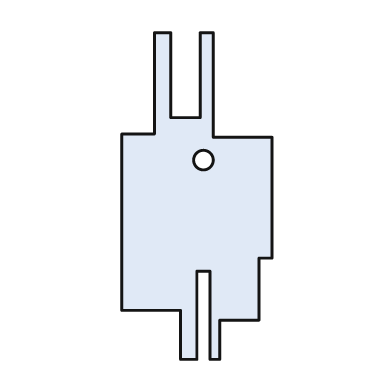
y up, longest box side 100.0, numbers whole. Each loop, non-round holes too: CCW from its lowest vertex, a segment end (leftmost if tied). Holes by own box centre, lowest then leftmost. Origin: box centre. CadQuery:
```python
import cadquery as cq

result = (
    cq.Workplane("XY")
    .moveTo(-5.0, -50.0)
    .lineTo(0.0, -50.0)
    .lineTo(0.0, -23.0)
    .lineTo(4.0, -23.0)
    .lineTo(4.0, -50.0)
    .lineTo(7.0, -50.0)
    .lineTo(7.0, -38.0)
    .lineTo(19.0, -38.0)
    .lineTo(19.0, -19.0)
    .lineTo(23.0, -19.0)
    .lineTo(23.0, 18.0)
    .lineTo(5.0, 18.0)
    .lineTo(5.0, 50.0)
    .lineTo(1.0, 50.0)
    .lineTo(1.0, 24.0)
    .lineTo(-8.0, 24.0)
    .lineTo(-8.0, 50.0)
    .lineTo(-13.0, 50.0)
    .lineTo(-13.0, 19.0)
    .lineTo(-23.0, 19.0)
    .lineTo(-23.0, -35.0)
    .lineTo(-5.0, -35.0)
    .close()
    .moveTo(2.0, 11.0)
    .circle(3.0)
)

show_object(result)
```